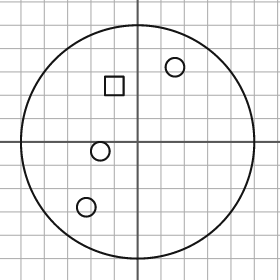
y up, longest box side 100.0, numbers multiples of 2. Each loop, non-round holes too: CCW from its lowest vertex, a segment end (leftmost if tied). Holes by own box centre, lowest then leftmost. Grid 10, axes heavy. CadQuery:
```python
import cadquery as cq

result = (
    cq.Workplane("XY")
    .moveTo(0.0, 0.0)
    .circle(50.0)
    .moveTo(-22.0, -28.0)
    .circle(4.0)
    .moveTo(-16.0, -4.0)
    .circle(4.0)
    .moveTo(-14.0, 20.0)
    .lineTo(-6.0, 20.0)
    .lineTo(-6.0, 28.0)
    .lineTo(-14.0, 28.0)
    .close()
    .moveTo(16.0, 32.0)
    .circle(4.0)
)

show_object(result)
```